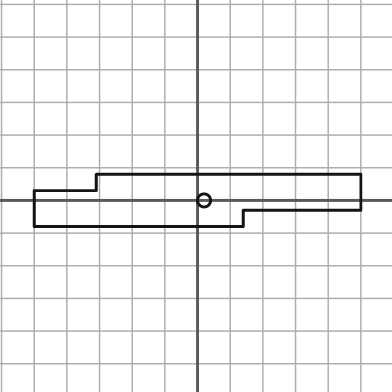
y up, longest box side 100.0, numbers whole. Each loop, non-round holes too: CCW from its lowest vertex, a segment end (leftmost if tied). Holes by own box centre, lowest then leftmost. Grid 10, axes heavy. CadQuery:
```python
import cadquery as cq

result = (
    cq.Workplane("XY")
    .moveTo(-50.0, -8.0)
    .lineTo(14.0, -8.0)
    .lineTo(14.0, -3.0)
    .lineTo(50.0, -3.0)
    .lineTo(50.0, 8.0)
    .lineTo(-31.0, 8.0)
    .lineTo(-31.0, 3.0)
    .lineTo(-50.0, 3.0)
    .close()
    .moveTo(2.0, 0.0)
    .circle(2.0)
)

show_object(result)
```